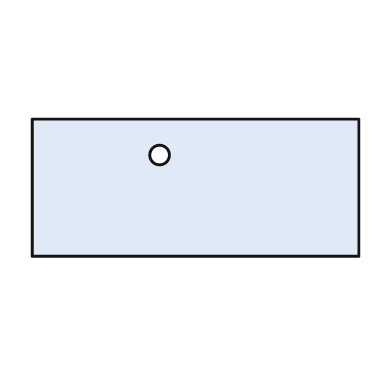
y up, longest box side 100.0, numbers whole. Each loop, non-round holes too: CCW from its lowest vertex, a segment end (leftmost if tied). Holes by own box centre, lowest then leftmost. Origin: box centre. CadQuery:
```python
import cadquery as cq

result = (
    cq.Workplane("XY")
    .moveTo(-50.0, -21.0)
    .lineTo(50.0, -21.0)
    .lineTo(50.0, 21.0)
    .lineTo(-50.0, 21.0)
    .close()
    .moveTo(-11.0, 10.0)
    .circle(3.0)
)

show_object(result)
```